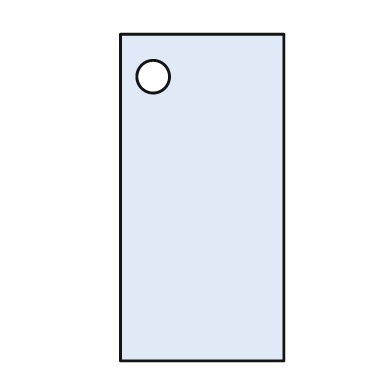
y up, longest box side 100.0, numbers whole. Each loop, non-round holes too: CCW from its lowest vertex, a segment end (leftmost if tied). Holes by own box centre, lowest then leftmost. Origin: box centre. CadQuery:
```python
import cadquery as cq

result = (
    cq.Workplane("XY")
    .moveTo(-25.0, -50.0)
    .lineTo(25.0, -50.0)
    .lineTo(25.0, 50.0)
    .lineTo(-25.0, 50.0)
    .close()
    .moveTo(-15.0, 37.0)
    .circle(5.0)
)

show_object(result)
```